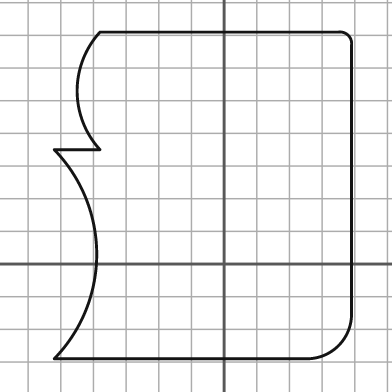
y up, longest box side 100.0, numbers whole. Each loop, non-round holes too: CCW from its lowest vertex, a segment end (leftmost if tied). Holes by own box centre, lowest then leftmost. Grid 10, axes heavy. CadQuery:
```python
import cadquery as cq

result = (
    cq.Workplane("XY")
    .moveTo(-52.0, -29.0)
    .lineTo(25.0, -29.0)
    .threePointArc((35.0, -25.0), (39.0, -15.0))
    .lineTo(39.0, 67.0)
    .threePointArc((38.0, 70.0), (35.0, 71.0))
    .lineTo(-38.0, 71.0)
    .threePointArc((-45.0, 53.0), (-38.0, 35.0))
    .lineTo(-52.0, 35.0)
    .threePointArc((-39.0, 3.0), (-52.0, -29.0))
    .close()
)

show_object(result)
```